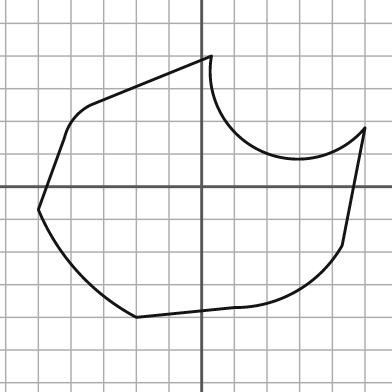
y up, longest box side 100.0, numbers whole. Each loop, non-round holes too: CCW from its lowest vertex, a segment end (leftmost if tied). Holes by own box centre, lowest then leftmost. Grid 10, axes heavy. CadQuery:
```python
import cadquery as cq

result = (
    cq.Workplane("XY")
    .moveTo(-20.0, -40.0)
    .lineTo(10.0, -37.0)
    .threePointArc((29.0, -32.0), (43.0, -18.0))
    .lineTo(50.0, 18.0)
    .threePointArc((18.0, 11.0), (3.0, 40.0))
    .lineTo(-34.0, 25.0)
    .threePointArc((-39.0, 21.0), (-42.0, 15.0))
    .lineTo(-50.0, -7.0)
    .threePointArc((-38.0, -26.0), (-20.0, -40.0))
    .close()
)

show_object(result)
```